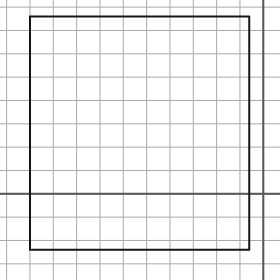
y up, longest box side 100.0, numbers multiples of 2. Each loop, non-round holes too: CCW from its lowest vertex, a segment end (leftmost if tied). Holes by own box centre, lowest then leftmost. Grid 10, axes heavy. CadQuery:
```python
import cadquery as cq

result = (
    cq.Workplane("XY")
    .moveTo(-100.0, -24.0)
    .lineTo(-6.0, -24.0)
    .lineTo(-6.0, 76.0)
    .lineTo(-100.0, 76.0)
    .close()
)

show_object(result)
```